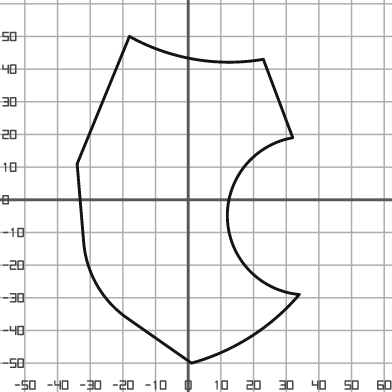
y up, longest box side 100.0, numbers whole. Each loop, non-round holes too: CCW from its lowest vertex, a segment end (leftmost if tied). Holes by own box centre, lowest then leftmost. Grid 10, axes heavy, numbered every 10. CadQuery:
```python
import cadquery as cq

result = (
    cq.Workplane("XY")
    .moveTo(1.0, -50.0)
    .threePointArc((19.0, -42.0), (34.0, -29.0))
    .threePointArc((12.0, -6.0), (32.0, 19.0))
    .lineTo(23.0, 43.0)
    .threePointArc((2.0, 43.0), (-18.0, 50.0))
    .lineTo(-34.0, 11.0)
    .lineTo(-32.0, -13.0)
    .threePointArc((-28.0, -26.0), (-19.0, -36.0))
    .close()
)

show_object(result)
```